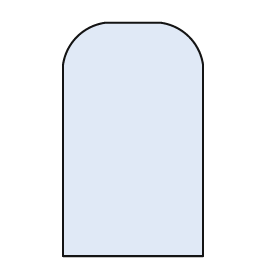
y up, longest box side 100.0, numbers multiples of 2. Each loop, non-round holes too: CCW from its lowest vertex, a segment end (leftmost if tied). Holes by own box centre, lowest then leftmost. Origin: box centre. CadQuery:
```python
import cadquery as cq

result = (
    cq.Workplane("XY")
    .moveTo(-30.0, -50.0)
    .lineTo(30.0, -50.0)
    .lineTo(30.0, 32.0)
    .threePointArc((24.0, 44.0), (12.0, 50.0))
    .lineTo(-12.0, 50.0)
    .threePointArc((-24.0, 44.0), (-30.0, 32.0))
    .close()
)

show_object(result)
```